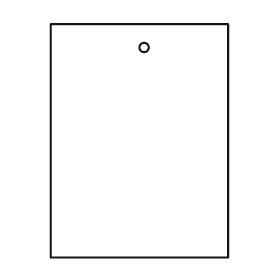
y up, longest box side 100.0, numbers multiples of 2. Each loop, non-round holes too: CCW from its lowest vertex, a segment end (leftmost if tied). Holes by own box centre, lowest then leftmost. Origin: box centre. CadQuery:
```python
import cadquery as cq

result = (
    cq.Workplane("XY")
    .moveTo(-38.0, -50.0)
    .lineTo(38.0, -50.0)
    .lineTo(38.0, 50.0)
    .lineTo(-38.0, 50.0)
    .close()
    .moveTo(2.0, 40.0)
    .circle(2.0)
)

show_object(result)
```